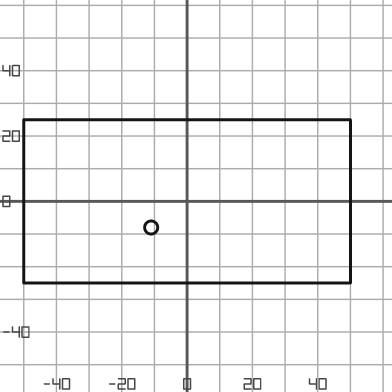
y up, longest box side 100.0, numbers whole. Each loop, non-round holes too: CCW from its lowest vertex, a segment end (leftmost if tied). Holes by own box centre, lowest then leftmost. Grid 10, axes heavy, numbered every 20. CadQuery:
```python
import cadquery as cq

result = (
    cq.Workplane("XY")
    .moveTo(-50.0, -25.0)
    .lineTo(50.0, -25.0)
    .lineTo(50.0, 25.0)
    .lineTo(-50.0, 25.0)
    .close()
    .moveTo(-11.0, -8.0)
    .circle(2.0)
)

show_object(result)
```